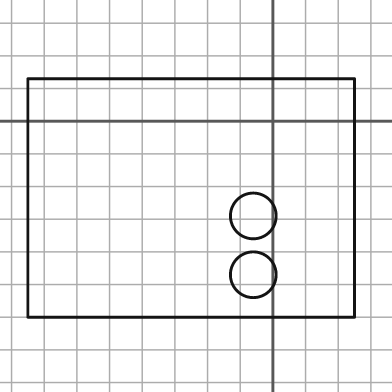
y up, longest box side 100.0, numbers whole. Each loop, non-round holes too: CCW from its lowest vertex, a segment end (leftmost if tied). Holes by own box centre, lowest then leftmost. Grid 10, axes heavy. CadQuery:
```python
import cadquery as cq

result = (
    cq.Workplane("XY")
    .moveTo(-75.0, -60.0)
    .lineTo(25.0, -60.0)
    .lineTo(25.0, 13.0)
    .lineTo(-75.0, 13.0)
    .close()
    .moveTo(-6.0, -47.0)
    .circle(7.0)
    .moveTo(-6.0, -29.0)
    .circle(7.0)
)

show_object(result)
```